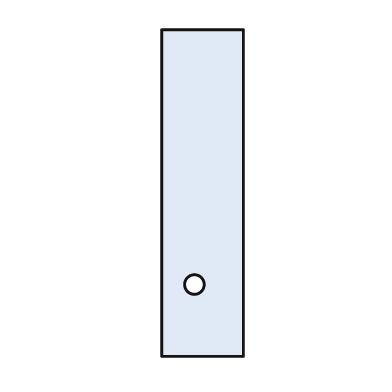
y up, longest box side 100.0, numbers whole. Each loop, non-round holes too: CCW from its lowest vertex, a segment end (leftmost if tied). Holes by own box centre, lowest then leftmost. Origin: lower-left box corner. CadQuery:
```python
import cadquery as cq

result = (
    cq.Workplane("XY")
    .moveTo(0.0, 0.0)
    .lineTo(25.0, 0.0)
    .lineTo(25.0, 100.0)
    .lineTo(0.0, 100.0)
    .close()
    .moveTo(10.0, 22.0)
    .circle(3.0)
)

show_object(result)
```